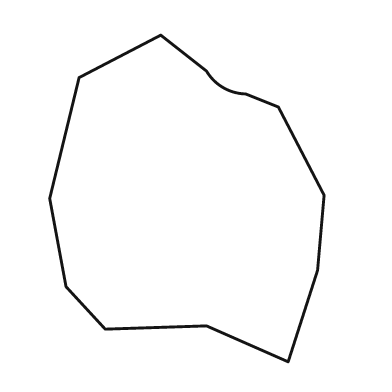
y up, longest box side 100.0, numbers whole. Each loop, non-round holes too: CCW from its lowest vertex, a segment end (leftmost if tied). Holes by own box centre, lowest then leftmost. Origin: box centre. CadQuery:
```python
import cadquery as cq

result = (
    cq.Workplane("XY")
    .moveTo(31.0, -50.0)
    .lineTo(40.0, -22.0)
    .lineTo(42.0, 1.0)
    .lineTo(28.0, 28.0)
    .lineTo(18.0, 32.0)
    .threePointArc((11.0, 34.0), (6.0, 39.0))
    .lineTo(-8.0, 50.0)
    .lineTo(-33.0, 37.0)
    .lineTo(-42.0, 0.0)
    .lineTo(-37.0, -27.0)
    .lineTo(-25.0, -40.0)
    .lineTo(6.0, -39.0)
    .close()
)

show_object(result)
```